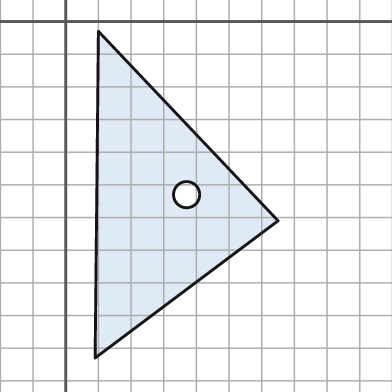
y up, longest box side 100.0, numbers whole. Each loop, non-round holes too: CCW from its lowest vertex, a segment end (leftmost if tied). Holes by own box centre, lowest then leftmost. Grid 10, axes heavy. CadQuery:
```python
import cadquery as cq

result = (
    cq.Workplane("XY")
    .moveTo(9.0, -103.0)
    .lineTo(65.0, -61.0)
    .lineTo(10.0, -3.0)
    .close()
    .moveTo(37.0, -53.0)
    .circle(4.0)
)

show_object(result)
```